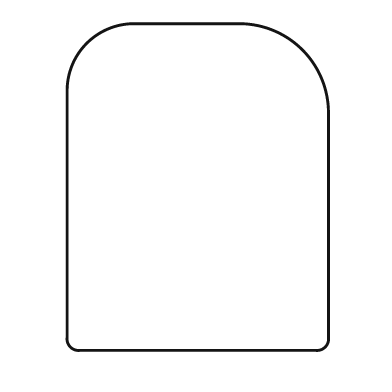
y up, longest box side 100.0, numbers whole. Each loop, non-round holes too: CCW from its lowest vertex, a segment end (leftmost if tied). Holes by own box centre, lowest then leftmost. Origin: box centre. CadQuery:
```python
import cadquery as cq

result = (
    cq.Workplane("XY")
    .moveTo(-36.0, -50.0)
    .lineTo(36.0, -50.0)
    .threePointArc((39.0, -49.0), (40.0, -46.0))
    .lineTo(40.0, 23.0)
    .threePointArc((32.0, 42.0), (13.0, 50.0))
    .lineTo(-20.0, 50.0)
    .threePointArc((-34.0, 44.0), (-40.0, 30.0))
    .lineTo(-40.0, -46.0)
    .threePointArc((-39.0, -49.0), (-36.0, -50.0))
    .close()
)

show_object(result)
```